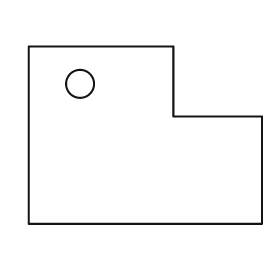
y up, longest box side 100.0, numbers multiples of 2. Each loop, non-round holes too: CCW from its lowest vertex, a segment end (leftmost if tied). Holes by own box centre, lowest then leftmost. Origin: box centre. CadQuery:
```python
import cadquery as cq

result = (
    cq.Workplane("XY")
    .moveTo(-50.0, -38.0)
    .lineTo(50.0, -38.0)
    .lineTo(50.0, 8.0)
    .lineTo(12.0, 8.0)
    .lineTo(12.0, 38.0)
    .lineTo(-50.0, 38.0)
    .close()
    .moveTo(-28.0, 22.0)
    .circle(6.0)
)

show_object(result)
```